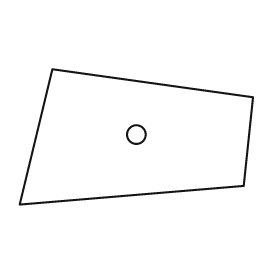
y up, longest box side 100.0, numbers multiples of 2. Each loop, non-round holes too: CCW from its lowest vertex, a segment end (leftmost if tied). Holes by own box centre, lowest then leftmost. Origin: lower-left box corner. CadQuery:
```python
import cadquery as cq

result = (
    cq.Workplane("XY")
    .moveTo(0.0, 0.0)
    .lineTo(96.0, 8.0)
    .lineTo(100.0, 46.0)
    .lineTo(14.0, 58.0)
    .close()
    .moveTo(50.0, 30.0)
    .circle(4.0)
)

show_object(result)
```